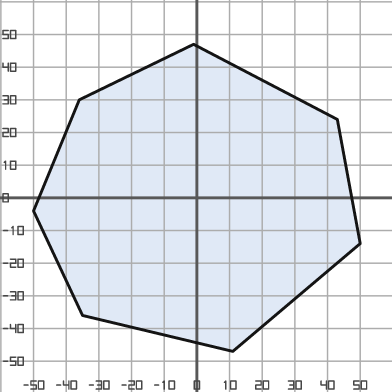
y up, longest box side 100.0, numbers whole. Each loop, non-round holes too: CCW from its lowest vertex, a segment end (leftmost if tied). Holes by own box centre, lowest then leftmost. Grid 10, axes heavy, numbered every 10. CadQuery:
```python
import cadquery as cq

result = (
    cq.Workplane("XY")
    .moveTo(11.0, -47.0)
    .lineTo(50.0, -14.0)
    .lineTo(43.0, 24.0)
    .lineTo(-1.0, 47.0)
    .lineTo(-36.0, 30.0)
    .lineTo(-50.0, -4.0)
    .lineTo(-35.0, -36.0)
    .close()
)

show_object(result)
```